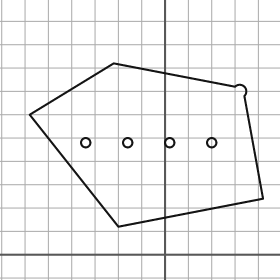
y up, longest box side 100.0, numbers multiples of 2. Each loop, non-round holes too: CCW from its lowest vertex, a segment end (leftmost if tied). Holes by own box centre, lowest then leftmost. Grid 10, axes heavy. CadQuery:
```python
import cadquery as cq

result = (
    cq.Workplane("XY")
    .moveTo(-20.0, 12.0)
    .lineTo(42.0, 24.0)
    .lineTo(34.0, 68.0)
    .threePointArc((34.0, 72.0), (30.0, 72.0))
    .lineTo(-22.0, 82.0)
    .lineTo(-58.0, 60.0)
    .close()
    .moveTo(-34.0, 48.0)
    .circle(2.0)
    .moveTo(-16.0, 48.0)
    .circle(2.0)
    .moveTo(2.0, 48.0)
    .circle(2.0)
    .moveTo(20.0, 48.0)
    .circle(2.0)
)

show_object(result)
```